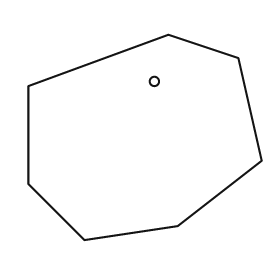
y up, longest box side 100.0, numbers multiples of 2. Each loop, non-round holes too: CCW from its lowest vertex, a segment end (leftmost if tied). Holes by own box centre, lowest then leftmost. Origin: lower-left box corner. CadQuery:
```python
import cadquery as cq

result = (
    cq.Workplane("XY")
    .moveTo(24.0, 0.0)
    .lineTo(64.0, 6.0)
    .lineTo(100.0, 34.0)
    .lineTo(90.0, 78.0)
    .lineTo(60.0, 88.0)
    .lineTo(0.0, 66.0)
    .lineTo(0.0, 24.0)
    .close()
    .moveTo(54.0, 68.0)
    .circle(2.0)
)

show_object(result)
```